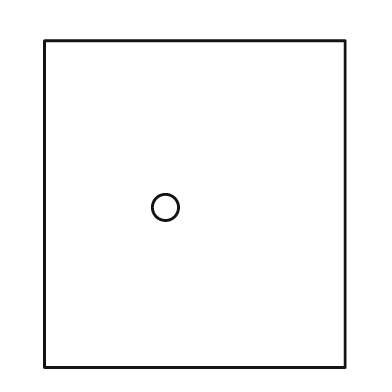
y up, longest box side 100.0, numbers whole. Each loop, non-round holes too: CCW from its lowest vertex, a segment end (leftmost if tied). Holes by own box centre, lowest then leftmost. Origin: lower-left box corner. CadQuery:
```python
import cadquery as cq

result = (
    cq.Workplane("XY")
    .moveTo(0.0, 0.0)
    .lineTo(92.0, 0.0)
    .lineTo(92.0, 100.0)
    .lineTo(0.0, 100.0)
    .close()
    .moveTo(37.0, 49.0)
    .circle(4.0)
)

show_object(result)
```